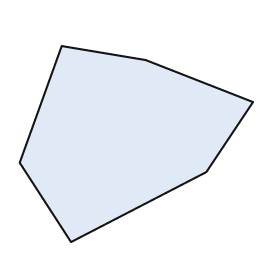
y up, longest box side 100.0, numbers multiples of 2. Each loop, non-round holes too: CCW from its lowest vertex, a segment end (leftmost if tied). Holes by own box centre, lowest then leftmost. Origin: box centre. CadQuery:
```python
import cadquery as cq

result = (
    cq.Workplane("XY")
    .moveTo(-28.0, -42.0)
    .lineTo(30.0, -12.0)
    .lineTo(50.0, 18.0)
    .lineTo(4.0, 36.0)
    .lineTo(-32.0, 42.0)
    .lineTo(-50.0, -8.0)
    .close()
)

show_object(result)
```